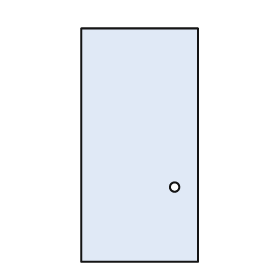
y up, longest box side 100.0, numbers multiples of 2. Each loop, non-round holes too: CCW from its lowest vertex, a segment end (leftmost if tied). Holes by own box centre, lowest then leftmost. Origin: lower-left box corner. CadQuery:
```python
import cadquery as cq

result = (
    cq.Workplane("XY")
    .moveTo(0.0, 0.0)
    .lineTo(50.0, 0.0)
    .lineTo(50.0, 100.0)
    .lineTo(0.0, 100.0)
    .close()
    .moveTo(40.0, 32.0)
    .circle(2.0)
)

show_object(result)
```